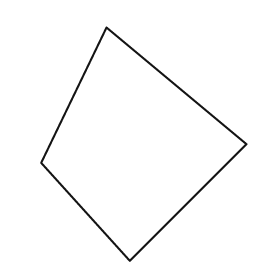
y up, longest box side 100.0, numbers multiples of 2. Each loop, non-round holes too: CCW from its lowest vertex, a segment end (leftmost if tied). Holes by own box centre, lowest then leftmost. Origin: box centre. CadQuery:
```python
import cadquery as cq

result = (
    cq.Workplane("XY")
    .moveTo(-6.0, -50.0)
    .lineTo(44.0, 0.0)
    .lineTo(-16.0, 50.0)
    .lineTo(-44.0, -8.0)
    .close()
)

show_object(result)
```